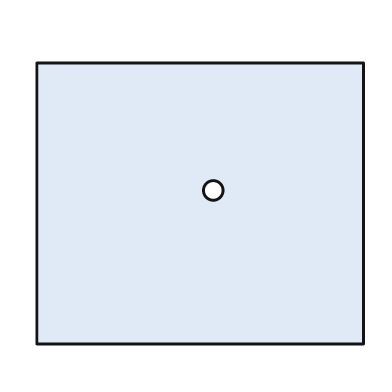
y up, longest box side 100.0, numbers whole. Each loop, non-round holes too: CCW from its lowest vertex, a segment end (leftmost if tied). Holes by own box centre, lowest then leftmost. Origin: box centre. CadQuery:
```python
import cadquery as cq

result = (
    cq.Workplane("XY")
    .moveTo(-50.0, -43.0)
    .lineTo(50.0, -43.0)
    .lineTo(50.0, 43.0)
    .lineTo(-50.0, 43.0)
    .close()
    .moveTo(4.0, 4.0)
    .circle(3.0)
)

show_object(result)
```